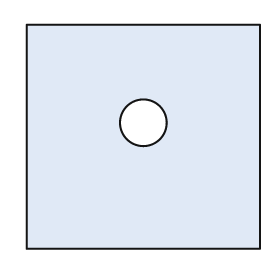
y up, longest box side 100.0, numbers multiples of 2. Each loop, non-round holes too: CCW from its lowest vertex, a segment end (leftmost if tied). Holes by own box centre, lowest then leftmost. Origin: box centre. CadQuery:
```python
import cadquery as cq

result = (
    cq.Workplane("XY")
    .moveTo(-50.0, -48.0)
    .lineTo(50.0, -48.0)
    .lineTo(50.0, 48.0)
    .lineTo(-50.0, 48.0)
    .close()
    .moveTo(0.0, 6.0)
    .circle(10.0)
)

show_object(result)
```